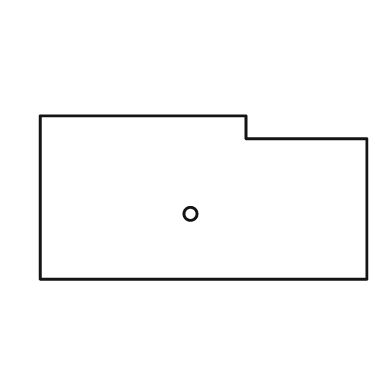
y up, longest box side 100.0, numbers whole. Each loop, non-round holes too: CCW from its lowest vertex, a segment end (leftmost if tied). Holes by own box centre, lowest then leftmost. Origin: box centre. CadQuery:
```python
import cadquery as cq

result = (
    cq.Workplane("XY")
    .moveTo(-50.0, -25.0)
    .lineTo(50.0, -25.0)
    .lineTo(50.0, 18.0)
    .lineTo(13.0, 18.0)
    .lineTo(13.0, 25.0)
    .lineTo(-50.0, 25.0)
    .close()
    .moveTo(-4.0, -5.0)
    .circle(2.0)
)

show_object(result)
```